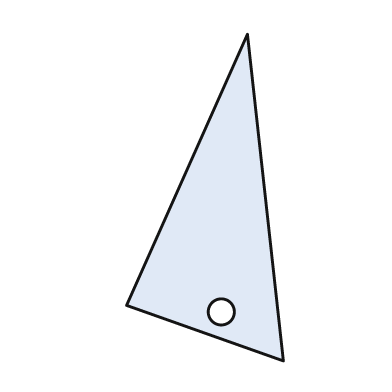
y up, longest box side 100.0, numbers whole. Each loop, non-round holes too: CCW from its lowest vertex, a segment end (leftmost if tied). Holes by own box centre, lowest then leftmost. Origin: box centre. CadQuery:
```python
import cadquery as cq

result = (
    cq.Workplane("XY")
    .moveTo(24.0, -50.0)
    .lineTo(13.0, 50.0)
    .lineTo(-24.0, -33.0)
    .close()
    .moveTo(5.0, -35.0)
    .circle(4.0)
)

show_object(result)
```